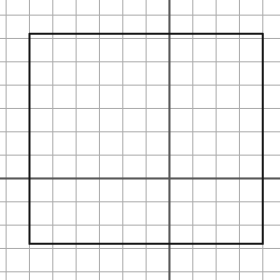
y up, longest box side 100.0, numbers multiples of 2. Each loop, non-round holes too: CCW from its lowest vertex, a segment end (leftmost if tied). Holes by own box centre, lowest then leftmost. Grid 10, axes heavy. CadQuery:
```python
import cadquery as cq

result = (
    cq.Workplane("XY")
    .moveTo(-60.0, -28.0)
    .lineTo(40.0, -28.0)
    .lineTo(40.0, 62.0)
    .lineTo(-60.0, 62.0)
    .close()
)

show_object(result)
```